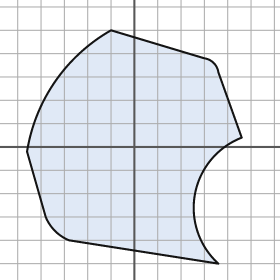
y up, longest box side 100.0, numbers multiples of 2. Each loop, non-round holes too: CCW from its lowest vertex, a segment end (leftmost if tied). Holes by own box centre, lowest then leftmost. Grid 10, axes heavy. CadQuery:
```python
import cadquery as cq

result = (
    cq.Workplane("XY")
    .moveTo(36.0, -50.0)
    .threePointArc((26.0, -20.0), (46.0, 4.0))
    .lineTo(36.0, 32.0)
    .threePointArc((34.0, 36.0), (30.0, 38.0))
    .lineTo(-10.0, 50.0)
    .threePointArc((-34.0, 28.0), (-46.0, -2.0))
    .lineTo(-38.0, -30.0)
    .threePointArc((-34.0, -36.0), (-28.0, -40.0))
    .close()
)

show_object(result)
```